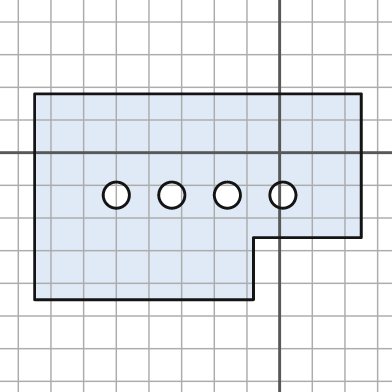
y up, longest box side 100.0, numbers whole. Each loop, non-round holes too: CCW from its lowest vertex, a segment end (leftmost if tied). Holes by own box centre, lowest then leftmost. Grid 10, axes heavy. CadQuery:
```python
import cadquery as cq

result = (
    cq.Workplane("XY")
    .moveTo(-75.0, -45.0)
    .lineTo(-8.0, -45.0)
    .lineTo(-8.0, -26.0)
    .lineTo(25.0, -26.0)
    .lineTo(25.0, 18.0)
    .lineTo(-75.0, 18.0)
    .close()
    .moveTo(-50.0, -13.0)
    .circle(4.0)
    .moveTo(-33.0, -13.0)
    .circle(4.0)
    .moveTo(-16.0, -13.0)
    .circle(4.0)
    .moveTo(1.0, -13.0)
    .circle(4.0)
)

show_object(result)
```